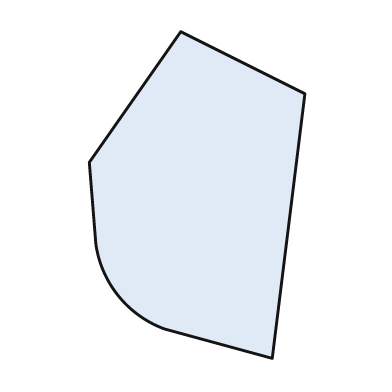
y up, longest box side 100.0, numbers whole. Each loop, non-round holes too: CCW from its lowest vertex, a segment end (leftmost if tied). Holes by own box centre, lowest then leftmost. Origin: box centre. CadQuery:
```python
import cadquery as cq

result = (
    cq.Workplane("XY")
    .moveTo(23.0, -50.0)
    .lineTo(33.0, 31.0)
    .lineTo(-5.0, 50.0)
    .lineTo(-33.0, 10.0)
    .lineTo(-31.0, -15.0)
    .threePointArc((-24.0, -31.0), (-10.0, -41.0))
    .close()
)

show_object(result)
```